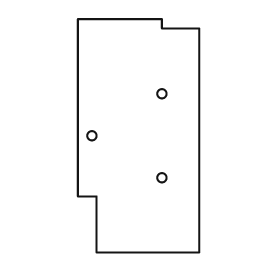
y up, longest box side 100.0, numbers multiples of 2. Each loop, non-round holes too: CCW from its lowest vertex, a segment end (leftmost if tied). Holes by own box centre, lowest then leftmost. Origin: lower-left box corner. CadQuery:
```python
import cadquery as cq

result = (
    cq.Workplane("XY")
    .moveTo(8.0, 0.0)
    .lineTo(52.0, 0.0)
    .lineTo(52.0, 96.0)
    .lineTo(36.0, 96.0)
    .lineTo(36.0, 100.0)
    .lineTo(0.0, 100.0)
    .lineTo(0.0, 24.0)
    .lineTo(8.0, 24.0)
    .close()
    .moveTo(36.0, 32.0)
    .circle(2.0)
    .moveTo(6.0, 50.0)
    .circle(2.0)
    .moveTo(36.0, 68.0)
    .circle(2.0)
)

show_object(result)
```